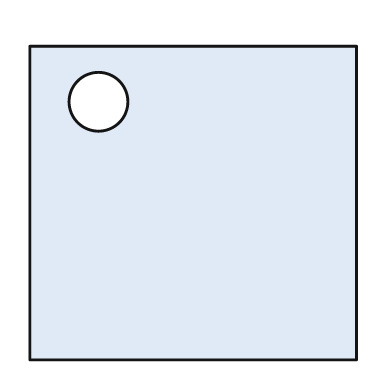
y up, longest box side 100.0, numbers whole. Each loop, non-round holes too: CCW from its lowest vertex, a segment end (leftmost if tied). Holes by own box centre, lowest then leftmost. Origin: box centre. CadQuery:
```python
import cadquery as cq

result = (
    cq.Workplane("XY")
    .moveTo(-50.0, -48.0)
    .lineTo(50.0, -48.0)
    .lineTo(50.0, 48.0)
    .lineTo(-50.0, 48.0)
    .close()
    .moveTo(-29.0, 31.0)
    .circle(9.0)
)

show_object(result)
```